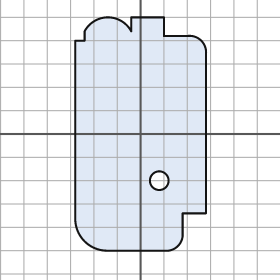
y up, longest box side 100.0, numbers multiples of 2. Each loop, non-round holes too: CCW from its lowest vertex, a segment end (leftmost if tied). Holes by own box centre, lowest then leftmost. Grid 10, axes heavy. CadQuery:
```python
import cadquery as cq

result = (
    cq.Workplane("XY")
    .moveTo(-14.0, -50.0)
    .lineTo(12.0, -50.0)
    .threePointArc((16.0, -48.0), (18.0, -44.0))
    .lineTo(18.0, -34.0)
    .lineTo(28.0, -34.0)
    .lineTo(28.0, 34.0)
    .threePointArc((26.0, 40.0), (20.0, 42.0))
    .lineTo(10.0, 42.0)
    .lineTo(10.0, 50.0)
    .lineTo(-4.0, 50.0)
    .lineTo(-4.0, 44.0)
    .threePointArc((-14.0, 50.0), (-24.0, 44.0))
    .lineTo(-24.0, 40.0)
    .lineTo(-28.0, 40.0)
    .lineTo(-28.0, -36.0)
    .threePointArc((-24.0, -46.0), (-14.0, -50.0))
    .close()
    .moveTo(8.0, -20.0)
    .circle(4.0)
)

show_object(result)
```